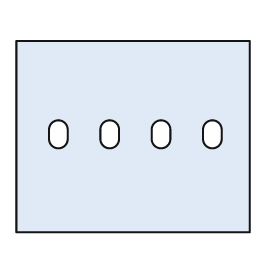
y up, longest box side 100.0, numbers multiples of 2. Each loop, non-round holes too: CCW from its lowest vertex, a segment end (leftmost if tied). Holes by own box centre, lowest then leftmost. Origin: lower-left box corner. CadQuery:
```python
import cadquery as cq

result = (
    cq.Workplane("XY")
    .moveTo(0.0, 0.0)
    .lineTo(100.0, 0.0)
    .lineTo(100.0, 82.0)
    .lineTo(0.0, 82.0)
    .close()
    .moveTo(14.0, 40.0)
    .threePointArc((18.0, 36.0), (22.0, 40.0))
    .lineTo(22.0, 44.0)
    .threePointArc((18.0, 48.0), (14.0, 44.0))
    .close()
    .moveTo(36.0, 40.0)
    .threePointArc((40.0, 36.0), (44.0, 40.0))
    .lineTo(44.0, 44.0)
    .threePointArc((40.0, 48.0), (36.0, 44.0))
    .close()
    .moveTo(58.0, 40.0)
    .threePointArc((62.0, 36.0), (66.0, 40.0))
    .lineTo(66.0, 44.0)
    .threePointArc((62.0, 48.0), (58.0, 44.0))
    .close()
    .moveTo(80.0, 40.0)
    .threePointArc((84.0, 36.0), (88.0, 40.0))
    .lineTo(88.0, 44.0)
    .threePointArc((84.0, 48.0), (80.0, 44.0))
    .close()
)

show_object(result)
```